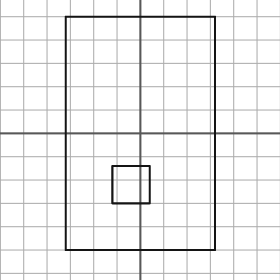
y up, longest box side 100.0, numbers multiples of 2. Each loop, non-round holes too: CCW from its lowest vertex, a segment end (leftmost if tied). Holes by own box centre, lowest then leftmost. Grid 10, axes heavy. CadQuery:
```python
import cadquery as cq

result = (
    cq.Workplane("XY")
    .moveTo(-32.0, -50.0)
    .lineTo(32.0, -50.0)
    .lineTo(32.0, 50.0)
    .lineTo(-32.0, 50.0)
    .close()
    .moveTo(-12.0, -30.0)
    .lineTo(4.0, -30.0)
    .lineTo(4.0, -14.0)
    .lineTo(-12.0, -14.0)
    .close()
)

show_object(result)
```